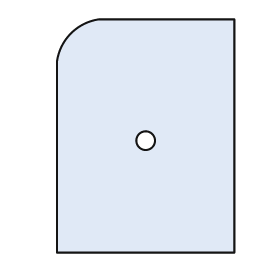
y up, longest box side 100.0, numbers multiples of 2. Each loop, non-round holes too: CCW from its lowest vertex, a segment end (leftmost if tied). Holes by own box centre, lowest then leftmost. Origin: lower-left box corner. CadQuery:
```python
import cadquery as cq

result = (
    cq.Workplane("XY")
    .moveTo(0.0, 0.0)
    .lineTo(76.0, 0.0)
    .lineTo(76.0, 100.0)
    .lineTo(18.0, 100.0)
    .threePointArc((6.0, 94.0), (0.0, 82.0))
    .close()
    .moveTo(38.0, 48.0)
    .circle(4.0)
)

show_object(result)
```